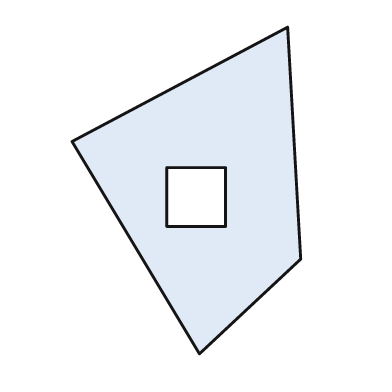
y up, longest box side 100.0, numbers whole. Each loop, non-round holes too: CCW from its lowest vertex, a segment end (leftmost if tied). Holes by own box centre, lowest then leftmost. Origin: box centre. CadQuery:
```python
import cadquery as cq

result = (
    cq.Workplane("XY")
    .moveTo(4.0, -50.0)
    .lineTo(35.0, -21.0)
    .lineTo(31.0, 50.0)
    .lineTo(-35.0, 15.0)
    .close()
    .moveTo(-6.0, -11.0)
    .lineTo(12.0, -11.0)
    .lineTo(12.0, 7.0)
    .lineTo(-6.0, 7.0)
    .close()
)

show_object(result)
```